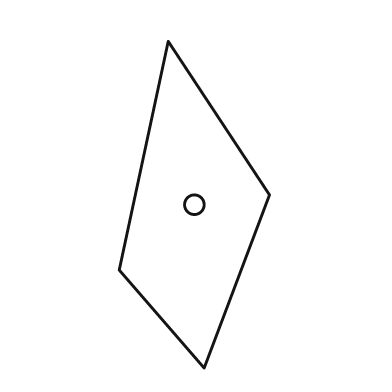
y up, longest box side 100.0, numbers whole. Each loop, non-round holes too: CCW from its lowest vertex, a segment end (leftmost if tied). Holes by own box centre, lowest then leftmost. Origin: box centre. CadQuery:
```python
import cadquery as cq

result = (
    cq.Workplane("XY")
    .moveTo(3.0, -50.0)
    .lineTo(23.0, 3.0)
    .lineTo(-8.0, 50.0)
    .lineTo(-23.0, -20.0)
    .close()
    .moveTo(0.0, 0.0)
    .circle(3.0)
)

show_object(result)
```